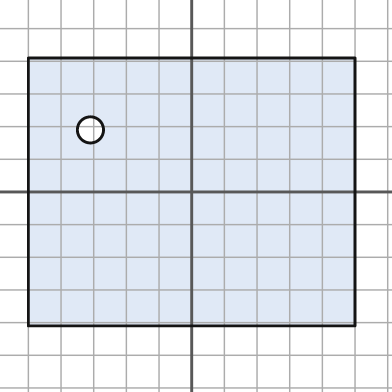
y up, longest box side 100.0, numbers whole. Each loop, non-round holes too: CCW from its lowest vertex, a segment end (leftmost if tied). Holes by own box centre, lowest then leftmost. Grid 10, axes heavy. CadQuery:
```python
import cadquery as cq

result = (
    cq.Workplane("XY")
    .moveTo(-50.0, -41.0)
    .lineTo(50.0, -41.0)
    .lineTo(50.0, 41.0)
    .lineTo(-50.0, 41.0)
    .close()
    .moveTo(-31.0, 19.0)
    .circle(4.0)
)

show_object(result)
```